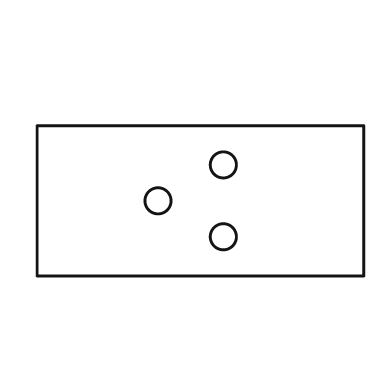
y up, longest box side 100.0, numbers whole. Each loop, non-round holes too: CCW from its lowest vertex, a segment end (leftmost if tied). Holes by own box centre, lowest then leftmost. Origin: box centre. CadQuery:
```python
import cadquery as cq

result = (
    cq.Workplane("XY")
    .moveTo(-50.0, -23.0)
    .lineTo(50.0, -23.0)
    .lineTo(50.0, 23.0)
    .lineTo(-50.0, 23.0)
    .close()
    .moveTo(7.0, -11.0)
    .circle(4.0)
    .moveTo(-13.0, 0.0)
    .circle(4.0)
    .moveTo(7.0, 11.0)
    .circle(4.0)
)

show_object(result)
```